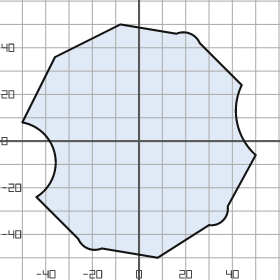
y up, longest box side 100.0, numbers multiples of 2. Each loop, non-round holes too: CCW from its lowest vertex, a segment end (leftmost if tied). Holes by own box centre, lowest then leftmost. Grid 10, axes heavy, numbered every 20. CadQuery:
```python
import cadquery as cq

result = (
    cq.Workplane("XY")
    .moveTo(8.0, -50.0)
    .lineTo(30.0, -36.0)
    .threePointArc((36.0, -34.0), (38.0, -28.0))
    .lineTo(50.0, -6.0)
    .threePointArc((42.0, 8.0), (44.0, 24.0))
    .lineTo(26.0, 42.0)
    .threePointArc((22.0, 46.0), (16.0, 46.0))
    .lineTo(-8.0, 50.0)
    .lineTo(-36.0, 36.0)
    .lineTo(-50.0, 8.0)
    .threePointArc((-36.0, -6.0), (-44.0, -24.0))
    .lineTo(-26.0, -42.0)
    .threePointArc((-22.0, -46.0), (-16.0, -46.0))
    .close()
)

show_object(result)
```